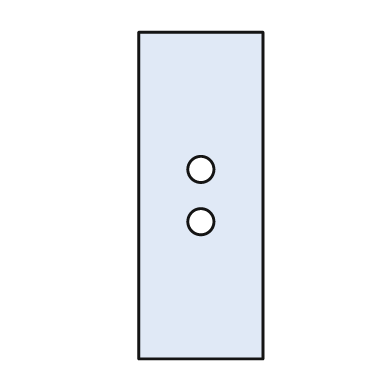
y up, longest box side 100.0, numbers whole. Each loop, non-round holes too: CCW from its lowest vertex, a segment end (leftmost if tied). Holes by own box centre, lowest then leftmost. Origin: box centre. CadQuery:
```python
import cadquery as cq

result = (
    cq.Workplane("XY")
    .moveTo(-19.0, -50.0)
    .lineTo(19.0, -50.0)
    .lineTo(19.0, 50.0)
    .lineTo(-19.0, 50.0)
    .close()
    .moveTo(0.0, -8.0)
    .circle(4.0)
    .moveTo(0.0, 8.0)
    .circle(4.0)
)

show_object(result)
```